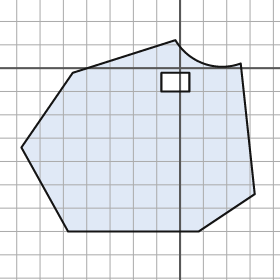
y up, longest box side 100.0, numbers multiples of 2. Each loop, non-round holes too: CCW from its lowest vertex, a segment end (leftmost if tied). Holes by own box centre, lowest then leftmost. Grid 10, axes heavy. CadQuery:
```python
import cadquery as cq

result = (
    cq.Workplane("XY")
    .moveTo(-48.0, -70.0)
    .lineTo(8.0, -70.0)
    .lineTo(32.0, -54.0)
    .lineTo(26.0, 2.0)
    .threePointArc((10.0, 2.0), (-2.0, 12.0))
    .lineTo(-46.0, -2.0)
    .lineTo(-68.0, -34.0)
    .close()
    .moveTo(-8.0, -10.0)
    .lineTo(4.0, -10.0)
    .lineTo(4.0, -2.0)
    .lineTo(-8.0, -2.0)
    .close()
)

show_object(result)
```